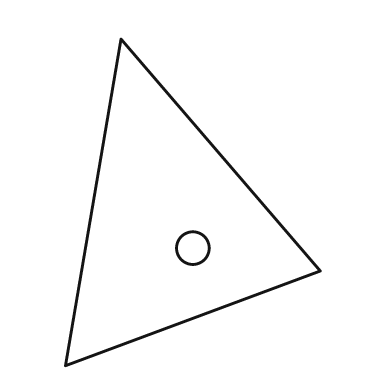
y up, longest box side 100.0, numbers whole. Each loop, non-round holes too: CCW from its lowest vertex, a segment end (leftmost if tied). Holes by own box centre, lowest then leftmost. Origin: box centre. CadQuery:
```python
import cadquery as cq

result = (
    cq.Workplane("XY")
    .moveTo(-39.0, -50.0)
    .lineTo(39.0, -21.0)
    .lineTo(-22.0, 50.0)
    .close()
    .moveTo(0.0, -14.0)
    .circle(5.0)
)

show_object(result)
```